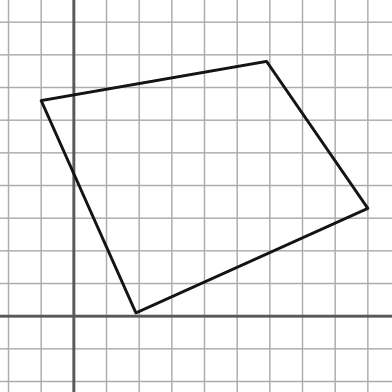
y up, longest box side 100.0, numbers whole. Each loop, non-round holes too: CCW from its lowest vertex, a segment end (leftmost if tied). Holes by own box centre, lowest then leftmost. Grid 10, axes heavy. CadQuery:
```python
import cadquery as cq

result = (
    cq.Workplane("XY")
    .moveTo(19.0, 1.0)
    .lineTo(90.0, 33.0)
    .lineTo(59.0, 78.0)
    .lineTo(-10.0, 66.0)
    .close()
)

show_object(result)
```